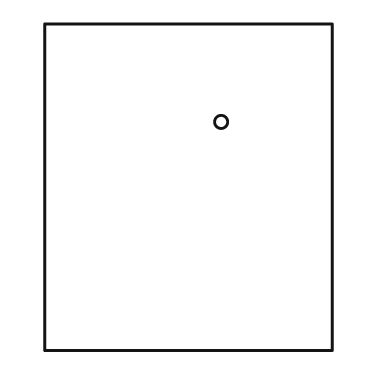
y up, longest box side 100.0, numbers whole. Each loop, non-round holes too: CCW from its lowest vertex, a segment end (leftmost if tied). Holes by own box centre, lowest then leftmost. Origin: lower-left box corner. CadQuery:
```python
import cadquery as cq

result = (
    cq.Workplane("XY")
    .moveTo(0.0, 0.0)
    .lineTo(88.0, 0.0)
    .lineTo(88.0, 100.0)
    .lineTo(0.0, 100.0)
    .close()
    .moveTo(54.0, 70.0)
    .circle(2.0)
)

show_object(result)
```